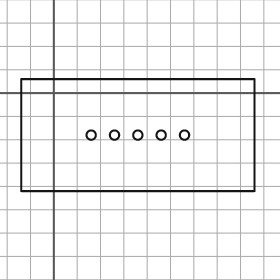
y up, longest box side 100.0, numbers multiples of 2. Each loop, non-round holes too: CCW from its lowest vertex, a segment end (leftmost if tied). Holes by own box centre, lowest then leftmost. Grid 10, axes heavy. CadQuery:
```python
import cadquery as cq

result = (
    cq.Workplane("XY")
    .moveTo(-14.0, -42.0)
    .lineTo(86.0, -42.0)
    .lineTo(86.0, 6.0)
    .lineTo(-14.0, 6.0)
    .close()
    .moveTo(16.0, -18.0)
    .circle(2.0)
    .moveTo(26.0, -18.0)
    .circle(2.0)
    .moveTo(36.0, -18.0)
    .circle(2.0)
    .moveTo(46.0, -18.0)
    .circle(2.0)
    .moveTo(56.0, -18.0)
    .circle(2.0)
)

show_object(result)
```